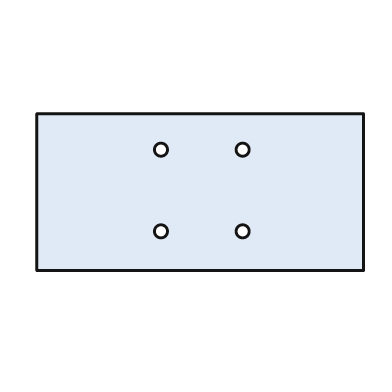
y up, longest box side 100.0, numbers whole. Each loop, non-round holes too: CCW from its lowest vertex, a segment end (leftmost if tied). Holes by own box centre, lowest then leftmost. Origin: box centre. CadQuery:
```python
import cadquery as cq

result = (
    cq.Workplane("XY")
    .moveTo(-50.0, -24.0)
    .lineTo(50.0, -24.0)
    .lineTo(50.0, 24.0)
    .lineTo(-50.0, 24.0)
    .close()
    .moveTo(-12.0, -12.0)
    .circle(2.0)
    .moveTo(13.0, -12.0)
    .circle(2.0)
    .moveTo(-12.0, 13.0)
    .circle(2.0)
    .moveTo(13.0, 13.0)
    .circle(2.0)
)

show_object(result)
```